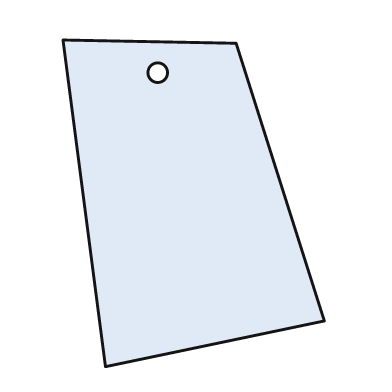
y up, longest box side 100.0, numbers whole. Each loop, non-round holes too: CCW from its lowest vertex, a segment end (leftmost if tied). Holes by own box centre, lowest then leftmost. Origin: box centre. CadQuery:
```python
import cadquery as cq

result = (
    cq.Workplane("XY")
    .moveTo(-27.0, -50.0)
    .lineTo(40.0, -36.0)
    .lineTo(13.0, 49.0)
    .lineTo(-40.0, 50.0)
    .close()
    .moveTo(-11.0, 40.0)
    .circle(3.0)
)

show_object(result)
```